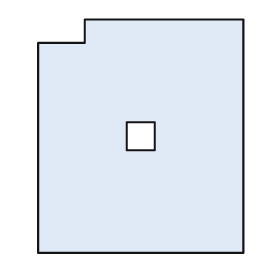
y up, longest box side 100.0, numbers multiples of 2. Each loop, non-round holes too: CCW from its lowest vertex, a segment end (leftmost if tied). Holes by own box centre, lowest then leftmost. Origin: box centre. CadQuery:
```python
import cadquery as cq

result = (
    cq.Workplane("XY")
    .moveTo(-44.0, -50.0)
    .lineTo(44.0, -50.0)
    .lineTo(44.0, 50.0)
    .lineTo(-24.0, 50.0)
    .lineTo(-24.0, 40.0)
    .lineTo(-44.0, 40.0)
    .close()
    .moveTo(-6.0, -6.0)
    .lineTo(6.0, -6.0)
    .lineTo(6.0, 6.0)
    .lineTo(-6.0, 6.0)
    .close()
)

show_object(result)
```